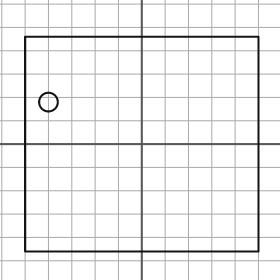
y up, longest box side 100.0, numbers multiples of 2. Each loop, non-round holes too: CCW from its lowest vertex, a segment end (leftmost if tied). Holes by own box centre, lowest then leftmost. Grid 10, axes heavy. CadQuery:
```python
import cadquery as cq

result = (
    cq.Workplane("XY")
    .moveTo(-50.0, -46.0)
    .lineTo(50.0, -46.0)
    .lineTo(50.0, 46.0)
    .lineTo(-50.0, 46.0)
    .close()
    .moveTo(-40.0, 18.0)
    .circle(4.0)
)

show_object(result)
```